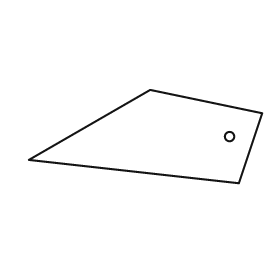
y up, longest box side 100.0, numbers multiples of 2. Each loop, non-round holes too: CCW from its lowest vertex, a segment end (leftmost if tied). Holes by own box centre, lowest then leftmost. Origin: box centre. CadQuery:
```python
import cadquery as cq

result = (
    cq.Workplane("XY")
    .moveTo(40.0, -20.0)
    .lineTo(50.0, 10.0)
    .lineTo(2.0, 20.0)
    .lineTo(-50.0, -10.0)
    .close()
    .moveTo(36.0, 0.0)
    .circle(2.0)
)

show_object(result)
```